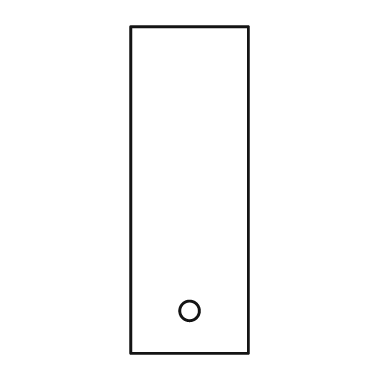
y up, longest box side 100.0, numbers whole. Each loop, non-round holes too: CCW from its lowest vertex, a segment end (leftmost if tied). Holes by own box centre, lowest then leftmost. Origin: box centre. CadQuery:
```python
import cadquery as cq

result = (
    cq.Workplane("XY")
    .moveTo(-18.0, -50.0)
    .lineTo(18.0, -50.0)
    .lineTo(18.0, 50.0)
    .lineTo(-18.0, 50.0)
    .close()
    .moveTo(0.0, -37.0)
    .circle(3.0)
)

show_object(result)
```